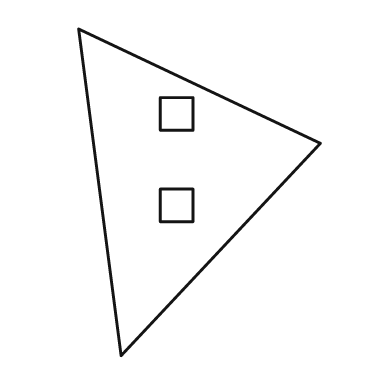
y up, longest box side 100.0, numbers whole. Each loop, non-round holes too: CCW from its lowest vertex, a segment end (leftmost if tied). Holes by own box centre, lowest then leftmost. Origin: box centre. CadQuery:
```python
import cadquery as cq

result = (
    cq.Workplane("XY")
    .moveTo(-24.0, -50.0)
    .lineTo(37.0, 15.0)
    .lineTo(-37.0, 50.0)
    .close()
    .moveTo(-12.0, -9.0)
    .lineTo(-2.0, -9.0)
    .lineTo(-2.0, 1.0)
    .lineTo(-12.0, 1.0)
    .close()
    .moveTo(-12.0, 19.0)
    .lineTo(-2.0, 19.0)
    .lineTo(-2.0, 29.0)
    .lineTo(-12.0, 29.0)
    .close()
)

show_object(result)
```